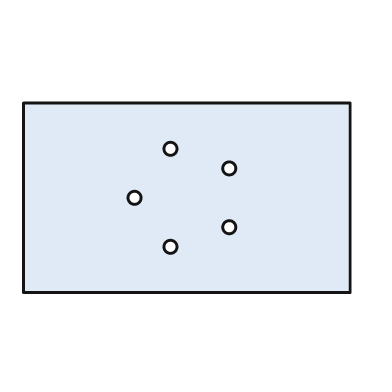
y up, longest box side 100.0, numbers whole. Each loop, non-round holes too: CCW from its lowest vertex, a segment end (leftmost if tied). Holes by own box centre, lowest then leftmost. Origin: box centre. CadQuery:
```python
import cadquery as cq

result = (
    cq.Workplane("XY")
    .moveTo(-50.0, -29.0)
    .lineTo(50.0, -29.0)
    .lineTo(50.0, 29.0)
    .lineTo(-50.0, 29.0)
    .close()
    .moveTo(-5.0, -15.0)
    .circle(2.0)
    .moveTo(13.0, -9.0)
    .circle(2.0)
    .moveTo(-16.0, 0.0)
    .circle(2.0)
    .moveTo(13.0, 9.0)
    .circle(2.0)
    .moveTo(-5.0, 15.0)
    .circle(2.0)
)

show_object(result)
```